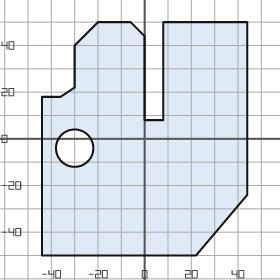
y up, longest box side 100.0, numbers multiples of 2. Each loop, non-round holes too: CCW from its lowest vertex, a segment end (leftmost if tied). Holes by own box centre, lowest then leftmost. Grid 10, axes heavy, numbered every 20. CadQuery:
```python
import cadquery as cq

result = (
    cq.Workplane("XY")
    .moveTo(-44.0, -50.0)
    .lineTo(22.0, -50.0)
    .lineTo(44.0, -24.0)
    .lineTo(44.0, 50.0)
    .lineTo(8.0, 50.0)
    .lineTo(8.0, 8.0)
    .lineTo(0.0, 8.0)
    .lineTo(0.0, 44.0)
    .lineTo(-6.0, 50.0)
    .lineTo(-20.0, 50.0)
    .lineTo(-30.0, 40.0)
    .lineTo(-30.0, 22.0)
    .lineTo(-36.0, 18.0)
    .lineTo(-44.0, 18.0)
    .close()
    .moveTo(-30.0, -4.0)
    .circle(8.0)
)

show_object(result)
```